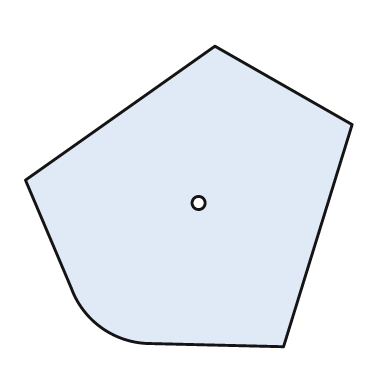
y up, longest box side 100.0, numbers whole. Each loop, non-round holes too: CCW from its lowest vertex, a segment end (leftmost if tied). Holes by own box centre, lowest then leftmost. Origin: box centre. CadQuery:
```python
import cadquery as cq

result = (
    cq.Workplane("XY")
    .moveTo(29.0, -46.0)
    .lineTo(50.0, 22.0)
    .lineTo(8.0, 46.0)
    .lineTo(-50.0, 5.0)
    .lineTo(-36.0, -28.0)
    .threePointArc((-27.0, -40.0), (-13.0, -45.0))
    .close()
    .moveTo(3.0, -2.0)
    .circle(2.0)
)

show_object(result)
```